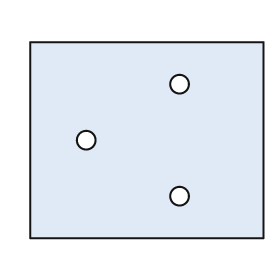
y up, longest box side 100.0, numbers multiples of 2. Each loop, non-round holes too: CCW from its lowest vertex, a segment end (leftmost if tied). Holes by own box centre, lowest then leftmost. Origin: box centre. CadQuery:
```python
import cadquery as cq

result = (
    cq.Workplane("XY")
    .moveTo(-50.0, -42.0)
    .lineTo(50.0, -42.0)
    .lineTo(50.0, 42.0)
    .lineTo(-50.0, 42.0)
    .close()
    .moveTo(14.0, -24.0)
    .circle(4.0)
    .moveTo(-26.0, 0.0)
    .circle(4.0)
    .moveTo(14.0, 24.0)
    .circle(4.0)
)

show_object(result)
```